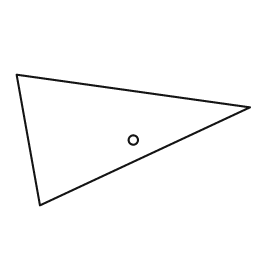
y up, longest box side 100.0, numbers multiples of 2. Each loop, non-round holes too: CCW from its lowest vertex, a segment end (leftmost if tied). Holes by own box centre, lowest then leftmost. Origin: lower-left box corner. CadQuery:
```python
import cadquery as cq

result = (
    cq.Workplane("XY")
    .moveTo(10.0, 0.0)
    .lineTo(100.0, 42.0)
    .lineTo(0.0, 56.0)
    .close()
    .moveTo(50.0, 28.0)
    .circle(2.0)
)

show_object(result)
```